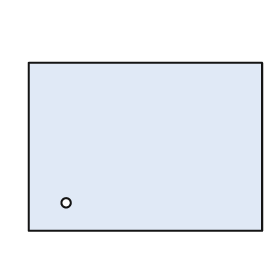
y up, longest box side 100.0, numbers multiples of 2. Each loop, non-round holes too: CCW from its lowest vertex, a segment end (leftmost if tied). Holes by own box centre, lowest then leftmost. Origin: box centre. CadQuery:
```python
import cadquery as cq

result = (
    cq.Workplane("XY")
    .moveTo(-50.0, -36.0)
    .lineTo(50.0, -36.0)
    .lineTo(50.0, 36.0)
    .lineTo(-50.0, 36.0)
    .close()
    .moveTo(-34.0, -24.0)
    .circle(2.0)
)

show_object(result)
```